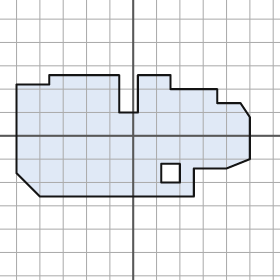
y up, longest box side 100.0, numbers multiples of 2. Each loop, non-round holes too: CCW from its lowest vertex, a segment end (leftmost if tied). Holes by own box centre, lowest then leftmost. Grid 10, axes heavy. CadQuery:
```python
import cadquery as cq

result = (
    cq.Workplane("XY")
    .moveTo(-40.0, -26.0)
    .lineTo(26.0, -26.0)
    .lineTo(26.0, -14.0)
    .lineTo(40.0, -14.0)
    .lineTo(50.0, -10.0)
    .lineTo(50.0, 8.0)
    .lineTo(46.0, 14.0)
    .lineTo(36.0, 14.0)
    .lineTo(36.0, 20.0)
    .lineTo(16.0, 20.0)
    .lineTo(16.0, 26.0)
    .lineTo(2.0, 26.0)
    .lineTo(2.0, 10.0)
    .lineTo(-6.0, 10.0)
    .lineTo(-6.0, 26.0)
    .lineTo(-36.0, 26.0)
    .lineTo(-36.0, 22.0)
    .lineTo(-50.0, 22.0)
    .lineTo(-50.0, -16.0)
    .close()
    .moveTo(12.0, -20.0)
    .lineTo(20.0, -20.0)
    .lineTo(20.0, -12.0)
    .lineTo(12.0, -12.0)
    .close()
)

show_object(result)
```